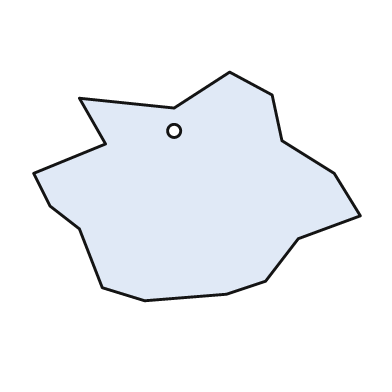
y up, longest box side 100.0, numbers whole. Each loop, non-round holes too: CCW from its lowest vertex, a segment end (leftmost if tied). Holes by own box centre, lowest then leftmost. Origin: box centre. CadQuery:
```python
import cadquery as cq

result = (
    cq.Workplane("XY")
    .moveTo(-16.0, -35.0)
    .lineTo(9.0, -33.0)
    .lineTo(21.0, -29.0)
    .lineTo(31.0, -16.0)
    .lineTo(50.0, -9.0)
    .lineTo(42.0, 4.0)
    .lineTo(26.0, 14.0)
    .lineTo(23.0, 28.0)
    .lineTo(10.0, 35.0)
    .lineTo(-7.0, 24.0)
    .lineTo(-36.0, 27.0)
    .lineTo(-28.0, 13.0)
    .lineTo(-50.0, 4.0)
    .lineTo(-45.0, -6.0)
    .lineTo(-36.0, -13.0)
    .lineTo(-29.0, -31.0)
    .close()
    .moveTo(-7.0, 17.0)
    .circle(2.0)
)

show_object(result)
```